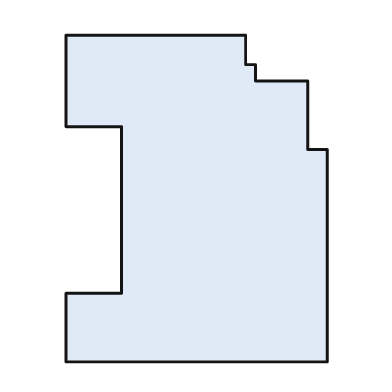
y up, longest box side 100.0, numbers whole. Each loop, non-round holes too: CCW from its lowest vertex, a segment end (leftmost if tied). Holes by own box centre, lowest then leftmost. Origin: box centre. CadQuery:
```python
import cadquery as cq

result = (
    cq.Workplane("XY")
    .moveTo(-40.0, -50.0)
    .lineTo(40.0, -50.0)
    .lineTo(40.0, 15.0)
    .lineTo(34.0, 15.0)
    .lineTo(34.0, 36.0)
    .lineTo(18.0, 36.0)
    .lineTo(18.0, 41.0)
    .lineTo(15.0, 41.0)
    .lineTo(15.0, 50.0)
    .lineTo(-40.0, 50.0)
    .lineTo(-40.0, 22.0)
    .lineTo(-23.0, 22.0)
    .lineTo(-23.0, -29.0)
    .lineTo(-40.0, -29.0)
    .close()
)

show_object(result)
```